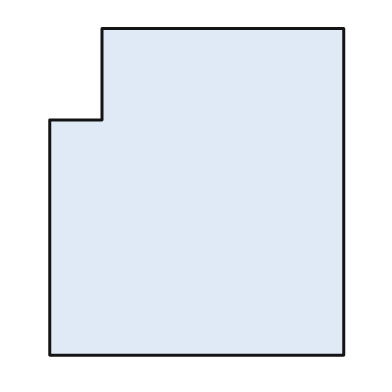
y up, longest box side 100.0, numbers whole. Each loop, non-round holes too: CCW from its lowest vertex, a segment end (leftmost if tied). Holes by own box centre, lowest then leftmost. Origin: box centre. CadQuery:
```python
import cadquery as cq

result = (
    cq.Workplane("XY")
    .moveTo(-45.0, -50.0)
    .lineTo(45.0, -50.0)
    .lineTo(45.0, 50.0)
    .lineTo(-29.0, 50.0)
    .lineTo(-29.0, 22.0)
    .lineTo(-45.0, 22.0)
    .close()
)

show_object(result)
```